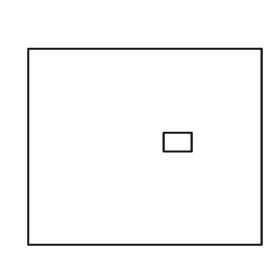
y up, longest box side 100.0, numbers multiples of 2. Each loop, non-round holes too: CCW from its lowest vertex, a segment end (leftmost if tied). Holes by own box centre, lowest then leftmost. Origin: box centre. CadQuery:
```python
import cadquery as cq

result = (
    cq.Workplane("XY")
    .moveTo(-50.0, -42.0)
    .lineTo(50.0, -42.0)
    .lineTo(50.0, 42.0)
    .lineTo(-50.0, 42.0)
    .close()
    .moveTo(8.0, -2.0)
    .lineTo(20.0, -2.0)
    .lineTo(20.0, 6.0)
    .lineTo(8.0, 6.0)
    .close()
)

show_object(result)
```